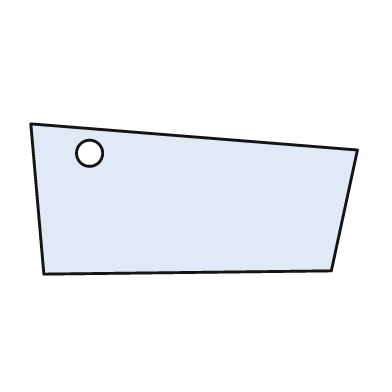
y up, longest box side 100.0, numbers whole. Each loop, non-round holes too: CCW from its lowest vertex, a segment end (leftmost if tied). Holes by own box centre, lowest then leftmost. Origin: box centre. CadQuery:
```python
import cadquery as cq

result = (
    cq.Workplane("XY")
    .moveTo(-46.0, -23.0)
    .lineTo(42.0, -22.0)
    .lineTo(50.0, 15.0)
    .lineTo(-50.0, 23.0)
    .close()
    .moveTo(-32.0, 14.0)
    .circle(4.0)
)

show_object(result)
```